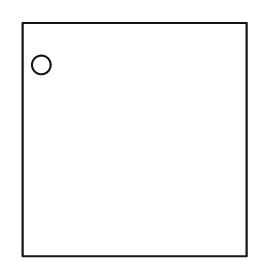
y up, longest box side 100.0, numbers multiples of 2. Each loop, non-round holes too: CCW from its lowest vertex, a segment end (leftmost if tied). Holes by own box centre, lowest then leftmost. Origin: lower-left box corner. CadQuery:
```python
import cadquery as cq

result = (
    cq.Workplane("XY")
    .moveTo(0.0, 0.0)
    .lineTo(96.0, 0.0)
    .lineTo(96.0, 100.0)
    .lineTo(0.0, 100.0)
    .close()
    .moveTo(8.0, 82.0)
    .circle(4.0)
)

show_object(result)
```